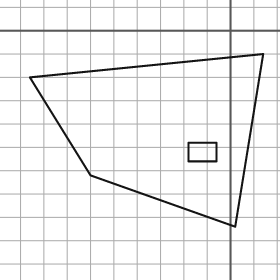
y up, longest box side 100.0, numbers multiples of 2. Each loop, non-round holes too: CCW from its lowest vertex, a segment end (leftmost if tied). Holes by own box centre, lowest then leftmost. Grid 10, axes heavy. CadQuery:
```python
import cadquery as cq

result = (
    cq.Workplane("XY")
    .moveTo(2.0, -84.0)
    .lineTo(14.0, -10.0)
    .lineTo(-86.0, -20.0)
    .lineTo(-60.0, -62.0)
    .close()
    .moveTo(-18.0, -56.0)
    .lineTo(-6.0, -56.0)
    .lineTo(-6.0, -48.0)
    .lineTo(-18.0, -48.0)
    .close()
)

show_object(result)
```